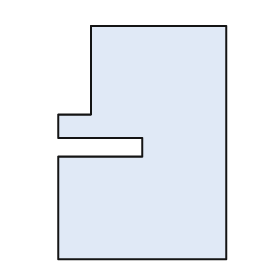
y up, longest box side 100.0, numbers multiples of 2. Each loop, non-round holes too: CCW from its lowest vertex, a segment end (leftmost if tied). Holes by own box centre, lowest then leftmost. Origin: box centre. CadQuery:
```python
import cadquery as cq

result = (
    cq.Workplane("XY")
    .moveTo(-36.0, -50.0)
    .lineTo(36.0, -50.0)
    .lineTo(36.0, 50.0)
    .lineTo(-22.0, 50.0)
    .lineTo(-22.0, 12.0)
    .lineTo(-36.0, 12.0)
    .lineTo(-36.0, 2.0)
    .lineTo(0.0, 2.0)
    .lineTo(0.0, -6.0)
    .lineTo(-36.0, -6.0)
    .close()
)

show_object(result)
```